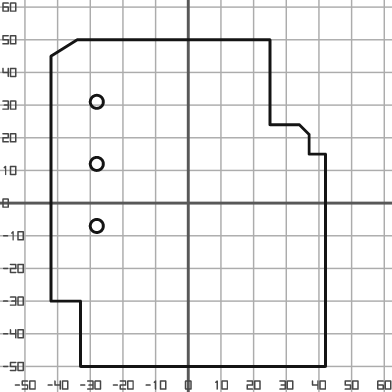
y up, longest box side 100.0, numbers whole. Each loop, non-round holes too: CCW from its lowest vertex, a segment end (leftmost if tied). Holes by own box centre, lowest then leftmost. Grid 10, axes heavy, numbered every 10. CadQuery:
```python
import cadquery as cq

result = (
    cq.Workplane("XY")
    .moveTo(-33.0, -50.0)
    .lineTo(42.0, -50.0)
    .lineTo(42.0, 15.0)
    .lineTo(37.0, 15.0)
    .lineTo(37.0, 21.0)
    .lineTo(34.0, 24.0)
    .lineTo(25.0, 24.0)
    .lineTo(25.0, 50.0)
    .lineTo(-34.0, 50.0)
    .lineTo(-42.0, 45.0)
    .lineTo(-42.0, -30.0)
    .lineTo(-33.0, -30.0)
    .close()
    .moveTo(-28.0, -7.0)
    .circle(2.0)
    .moveTo(-28.0, 12.0)
    .circle(2.0)
    .moveTo(-28.0, 31.0)
    .circle(2.0)
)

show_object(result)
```